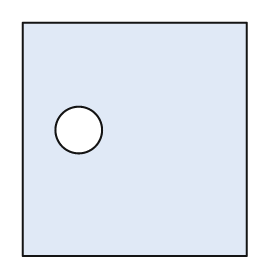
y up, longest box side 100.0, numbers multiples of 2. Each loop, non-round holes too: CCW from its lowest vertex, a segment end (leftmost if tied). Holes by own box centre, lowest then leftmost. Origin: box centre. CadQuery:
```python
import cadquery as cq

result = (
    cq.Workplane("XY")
    .moveTo(-48.0, -50.0)
    .lineTo(48.0, -50.0)
    .lineTo(48.0, 50.0)
    .lineTo(-48.0, 50.0)
    .close()
    .moveTo(-24.0, 4.0)
    .circle(10.0)
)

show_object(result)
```